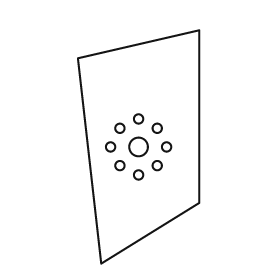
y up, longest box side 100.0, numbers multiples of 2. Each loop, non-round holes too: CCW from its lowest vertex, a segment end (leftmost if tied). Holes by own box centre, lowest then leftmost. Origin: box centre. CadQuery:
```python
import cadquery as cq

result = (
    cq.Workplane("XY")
    .moveTo(-16.0, -50.0)
    .lineTo(26.0, -24.0)
    .lineTo(26.0, 50.0)
    .lineTo(-26.0, 38.0)
    .close()
    .moveTo(0.0, -12.0)
    .circle(2.0)
    .moveTo(-8.0, -8.0)
    .circle(2.0)
    .moveTo(8.0, -8.0)
    .circle(2.0)
    .moveTo(-12.0, 0.0)
    .circle(2.0)
    .moveTo(0.0, 0.0)
    .circle(4.0)
    .moveTo(12.0, 0.0)
    .circle(2.0)
    .moveTo(-8.0, 8.0)
    .circle(2.0)
    .moveTo(8.0, 8.0)
    .circle(2.0)
    .moveTo(0.0, 12.0)
    .circle(2.0)
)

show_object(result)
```